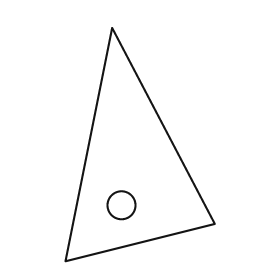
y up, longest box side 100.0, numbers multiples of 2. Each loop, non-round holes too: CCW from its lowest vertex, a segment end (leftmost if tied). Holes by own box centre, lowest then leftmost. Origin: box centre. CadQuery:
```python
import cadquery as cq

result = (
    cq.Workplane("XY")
    .moveTo(-32.0, -50.0)
    .lineTo(32.0, -34.0)
    .lineTo(-12.0, 50.0)
    .close()
    .moveTo(-8.0, -26.0)
    .circle(6.0)
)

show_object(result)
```